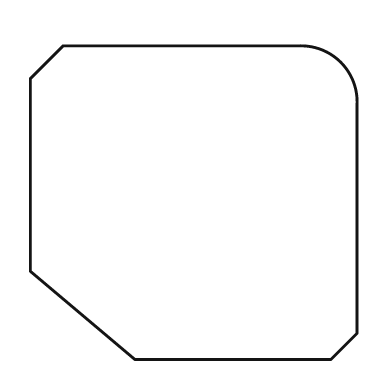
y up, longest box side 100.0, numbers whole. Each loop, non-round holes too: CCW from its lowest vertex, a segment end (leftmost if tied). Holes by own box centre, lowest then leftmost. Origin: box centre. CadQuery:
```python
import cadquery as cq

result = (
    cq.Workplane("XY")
    .moveTo(-18.0, -48.0)
    .lineTo(42.0, -48.0)
    .lineTo(50.0, -40.0)
    .lineTo(50.0, 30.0)
    .threePointArc((45.0, 43.0), (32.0, 48.0))
    .lineTo(-40.0, 48.0)
    .lineTo(-50.0, 38.0)
    .lineTo(-50.0, -21.0)
    .close()
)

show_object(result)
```